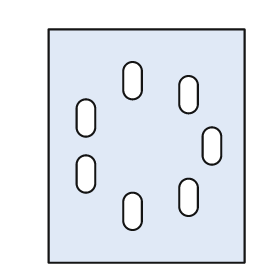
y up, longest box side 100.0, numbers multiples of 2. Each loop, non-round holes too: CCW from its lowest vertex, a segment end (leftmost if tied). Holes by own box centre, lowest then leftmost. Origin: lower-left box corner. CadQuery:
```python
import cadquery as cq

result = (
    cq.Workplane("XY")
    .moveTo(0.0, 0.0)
    .lineTo(84.0, 0.0)
    .lineTo(84.0, 100.0)
    .lineTo(0.0, 100.0)
    .close()
    .moveTo(32.0, 18.0)
    .threePointArc((36.0, 14.0), (40.0, 18.0))
    .lineTo(40.0, 26.0)
    .threePointArc((36.0, 30.0), (32.0, 26.0))
    .close()
    .moveTo(56.0, 24.0)
    .threePointArc((60.0, 20.0), (64.0, 24.0))
    .lineTo(64.0, 32.0)
    .threePointArc((60.0, 36.0), (56.0, 32.0))
    .close()
    .moveTo(12.0, 34.0)
    .threePointArc((16.0, 30.0), (20.0, 34.0))
    .lineTo(20.0, 42.0)
    .threePointArc((16.0, 46.0), (12.0, 42.0))
    .close()
    .moveTo(66.0, 46.0)
    .threePointArc((70.0, 42.0), (74.0, 46.0))
    .lineTo(74.0, 54.0)
    .threePointArc((70.0, 58.0), (66.0, 54.0))
    .close()
    .moveTo(12.0, 58.0)
    .threePointArc((16.0, 54.0), (20.0, 58.0))
    .lineTo(20.0, 66.0)
    .threePointArc((16.0, 70.0), (12.0, 66.0))
    .close()
    .moveTo(56.0, 68.0)
    .threePointArc((60.0, 64.0), (64.0, 68.0))
    .lineTo(64.0, 76.0)
    .threePointArc((60.0, 80.0), (56.0, 76.0))
    .close()
    .moveTo(32.0, 74.0)
    .threePointArc((36.0, 70.0), (40.0, 74.0))
    .lineTo(40.0, 82.0)
    .threePointArc((36.0, 86.0), (32.0, 82.0))
    .close()
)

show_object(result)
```